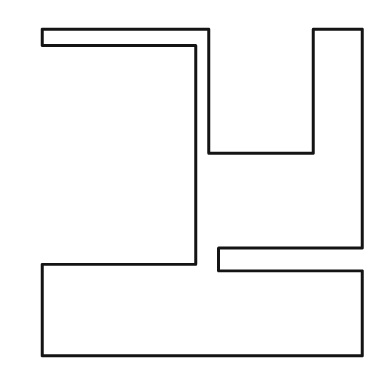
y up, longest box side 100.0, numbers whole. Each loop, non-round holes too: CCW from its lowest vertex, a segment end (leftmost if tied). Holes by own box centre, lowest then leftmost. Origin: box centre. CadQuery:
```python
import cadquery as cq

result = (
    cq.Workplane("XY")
    .moveTo(-49.0, -50.0)
    .lineTo(49.0, -50.0)
    .lineTo(49.0, -24.0)
    .lineTo(5.0, -24.0)
    .lineTo(5.0, -17.0)
    .lineTo(49.0, -17.0)
    .lineTo(49.0, 50.0)
    .lineTo(34.0, 50.0)
    .lineTo(34.0, 12.0)
    .lineTo(2.0, 12.0)
    .lineTo(2.0, 50.0)
    .lineTo(-49.0, 50.0)
    .lineTo(-49.0, 45.0)
    .lineTo(-2.0, 45.0)
    .lineTo(-2.0, -22.0)
    .lineTo(-49.0, -22.0)
    .close()
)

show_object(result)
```